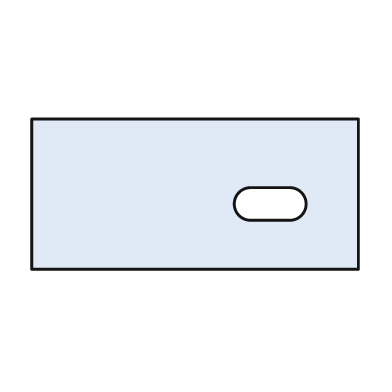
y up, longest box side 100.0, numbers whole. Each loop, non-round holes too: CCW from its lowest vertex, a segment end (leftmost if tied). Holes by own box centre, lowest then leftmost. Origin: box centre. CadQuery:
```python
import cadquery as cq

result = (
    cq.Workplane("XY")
    .moveTo(-50.0, -23.0)
    .lineTo(50.0, -23.0)
    .lineTo(50.0, 23.0)
    .lineTo(-50.0, 23.0)
    .close()
    .moveTo(17.0, -8.0)
    .lineTo(29.0, -8.0)
    .threePointArc((34.0, -3.0), (29.0, 2.0))
    .lineTo(17.0, 2.0)
    .threePointArc((12.0, -3.0), (17.0, -8.0))
    .close()
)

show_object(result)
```